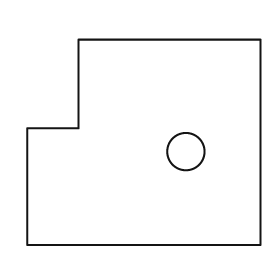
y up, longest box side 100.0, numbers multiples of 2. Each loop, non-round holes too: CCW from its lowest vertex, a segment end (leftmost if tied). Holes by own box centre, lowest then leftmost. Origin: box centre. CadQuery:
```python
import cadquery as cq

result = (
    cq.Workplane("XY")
    .moveTo(-50.0, -44.0)
    .lineTo(50.0, -44.0)
    .lineTo(50.0, 44.0)
    .lineTo(-28.0, 44.0)
    .lineTo(-28.0, 6.0)
    .lineTo(-50.0, 6.0)
    .close()
    .moveTo(18.0, -4.0)
    .circle(8.0)
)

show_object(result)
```